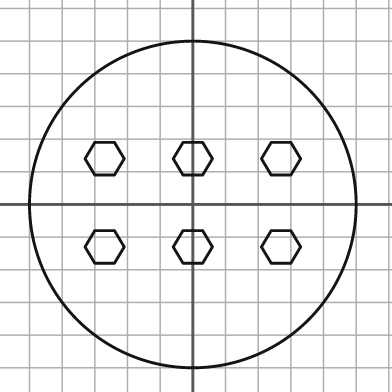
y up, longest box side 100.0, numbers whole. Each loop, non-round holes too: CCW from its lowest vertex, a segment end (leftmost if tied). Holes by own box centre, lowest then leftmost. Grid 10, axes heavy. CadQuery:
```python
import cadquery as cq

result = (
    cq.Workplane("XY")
    .moveTo(0.0, 0.0)
    .circle(50.0)
    .moveTo(-30.0, -18.0)
    .lineTo(-24.0, -18.0)
    .lineTo(-21.0, -13.0)
    .lineTo(-24.0, -8.0)
    .lineTo(-30.0, -8.0)
    .lineTo(-33.0, -13.0)
    .close()
    .moveTo(-3.0, -18.0)
    .lineTo(3.0, -18.0)
    .lineTo(6.0, -13.0)
    .lineTo(3.0, -8.0)
    .lineTo(-3.0, -8.0)
    .lineTo(-6.0, -13.0)
    .close()
    .moveTo(24.0, -18.0)
    .lineTo(30.0, -18.0)
    .lineTo(33.0, -13.0)
    .lineTo(30.0, -8.0)
    .lineTo(24.0, -8.0)
    .lineTo(21.0, -13.0)
    .close()
    .moveTo(-30.0, 9.0)
    .lineTo(-24.0, 9.0)
    .lineTo(-21.0, 14.0)
    .lineTo(-24.0, 19.0)
    .lineTo(-30.0, 19.0)
    .lineTo(-33.0, 14.0)
    .close()
    .moveTo(-3.0, 9.0)
    .lineTo(3.0, 9.0)
    .lineTo(6.0, 14.0)
    .lineTo(3.0, 19.0)
    .lineTo(-3.0, 19.0)
    .lineTo(-6.0, 14.0)
    .close()
    .moveTo(24.0, 9.0)
    .lineTo(30.0, 9.0)
    .lineTo(33.0, 14.0)
    .lineTo(30.0, 19.0)
    .lineTo(24.0, 19.0)
    .lineTo(21.0, 14.0)
    .close()
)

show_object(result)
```